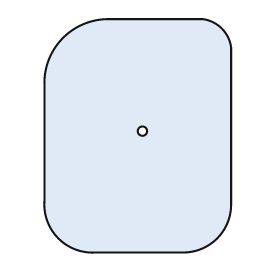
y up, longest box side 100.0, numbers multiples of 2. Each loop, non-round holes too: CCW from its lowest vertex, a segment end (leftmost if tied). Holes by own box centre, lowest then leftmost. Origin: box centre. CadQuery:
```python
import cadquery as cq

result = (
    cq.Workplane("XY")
    .moveTo(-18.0, -50.0)
    .lineTo(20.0, -50.0)
    .threePointArc((34.0, -44.0), (40.0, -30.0))
    .lineTo(40.0, 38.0)
    .threePointArc((36.0, 46.0), (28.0, 50.0))
    .lineTo(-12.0, 50.0)
    .threePointArc((-32.0, 42.0), (-40.0, 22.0))
    .lineTo(-40.0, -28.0)
    .threePointArc((-34.0, -44.0), (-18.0, -50.0))
    .close()
    .moveTo(2.0, 2.0)
    .circle(2.0)
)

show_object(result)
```